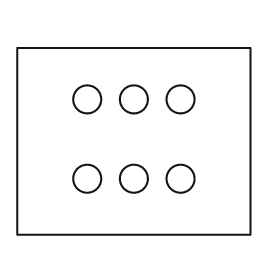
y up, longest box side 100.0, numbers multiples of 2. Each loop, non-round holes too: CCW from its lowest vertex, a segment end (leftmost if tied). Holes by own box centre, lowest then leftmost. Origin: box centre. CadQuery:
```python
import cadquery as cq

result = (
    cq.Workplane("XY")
    .moveTo(-50.0, -40.0)
    .lineTo(50.0, -40.0)
    .lineTo(50.0, 40.0)
    .lineTo(-50.0, 40.0)
    .close()
    .moveTo(-20.0, -16.0)
    .circle(6.0)
    .moveTo(0.0, -16.0)
    .circle(6.0)
    .moveTo(20.0, -16.0)
    .circle(6.0)
    .moveTo(-20.0, 18.0)
    .circle(6.0)
    .moveTo(0.0, 18.0)
    .circle(6.0)
    .moveTo(20.0, 18.0)
    .circle(6.0)
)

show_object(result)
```